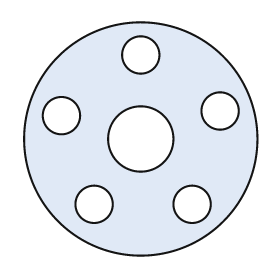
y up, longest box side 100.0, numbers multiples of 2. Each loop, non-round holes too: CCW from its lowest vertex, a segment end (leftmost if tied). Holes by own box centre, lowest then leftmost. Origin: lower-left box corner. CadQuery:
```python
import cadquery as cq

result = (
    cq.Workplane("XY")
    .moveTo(50.0, 50.0)
    .circle(50.0)
    .moveTo(30.0, 22.0)
    .circle(8.0)
    .moveTo(72.0, 22.0)
    .circle(8.0)
    .moveTo(50.0, 50.0)
    .circle(14.0)
    .moveTo(16.0, 60.0)
    .circle(8.0)
    .moveTo(84.0, 62.0)
    .circle(8.0)
    .moveTo(50.0, 86.0)
    .circle(8.0)
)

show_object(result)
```